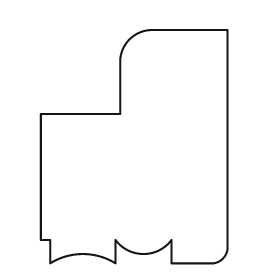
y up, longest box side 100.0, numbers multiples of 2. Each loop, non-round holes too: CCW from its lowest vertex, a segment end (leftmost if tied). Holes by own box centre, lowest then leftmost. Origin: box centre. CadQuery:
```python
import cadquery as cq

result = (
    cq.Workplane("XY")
    .moveTo(-36.0, -50.0)
    .threePointArc((-22.0, -46.0), (-8.0, -50.0))
    .lineTo(-8.0, -40.0)
    .threePointArc((4.0, -46.0), (16.0, -40.0))
    .lineTo(16.0, -50.0)
    .lineTo(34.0, -50.0)
    .threePointArc((38.0, -48.0), (40.0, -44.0))
    .lineTo(40.0, 50.0)
    .lineTo(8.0, 50.0)
    .threePointArc((-2.0, 46.0), (-6.0, 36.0))
    .lineTo(-6.0, 14.0)
    .lineTo(-40.0, 14.0)
    .lineTo(-40.0, -40.0)
    .lineTo(-36.0, -40.0)
    .close()
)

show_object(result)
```